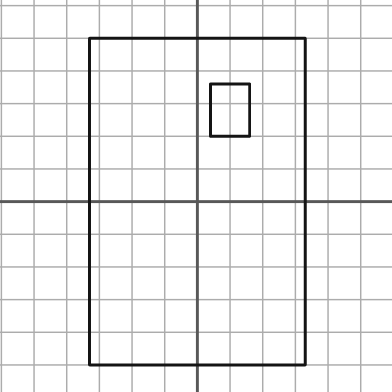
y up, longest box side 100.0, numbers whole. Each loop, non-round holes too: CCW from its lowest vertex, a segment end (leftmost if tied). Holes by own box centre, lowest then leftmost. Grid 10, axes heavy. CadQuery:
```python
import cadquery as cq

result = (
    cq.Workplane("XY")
    .moveTo(-33.0, -50.0)
    .lineTo(33.0, -50.0)
    .lineTo(33.0, 50.0)
    .lineTo(-33.0, 50.0)
    .close()
    .moveTo(4.0, 20.0)
    .lineTo(16.0, 20.0)
    .lineTo(16.0, 36.0)
    .lineTo(4.0, 36.0)
    .close()
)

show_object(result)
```